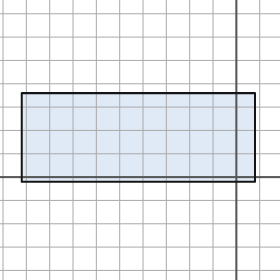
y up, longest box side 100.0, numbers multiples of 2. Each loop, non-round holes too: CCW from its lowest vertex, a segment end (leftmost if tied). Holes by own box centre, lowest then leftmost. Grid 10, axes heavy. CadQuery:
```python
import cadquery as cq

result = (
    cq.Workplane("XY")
    .moveTo(-92.0, -2.0)
    .lineTo(8.0, -2.0)
    .lineTo(8.0, 36.0)
    .lineTo(-92.0, 36.0)
    .close()
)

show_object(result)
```